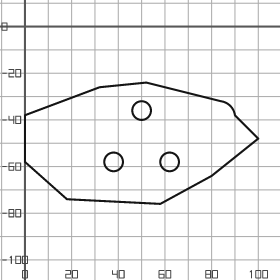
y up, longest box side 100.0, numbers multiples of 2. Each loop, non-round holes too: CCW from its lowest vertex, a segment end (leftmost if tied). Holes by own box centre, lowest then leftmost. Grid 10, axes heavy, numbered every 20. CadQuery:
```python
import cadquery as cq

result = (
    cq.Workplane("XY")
    .moveTo(58.0, -76.0)
    .lineTo(80.0, -64.0)
    .lineTo(100.0, -48.0)
    .lineTo(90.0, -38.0)
    .threePointArc((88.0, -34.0), (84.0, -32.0))
    .lineTo(52.0, -24.0)
    .lineTo(32.0, -26.0)
    .lineTo(0.0, -38.0)
    .lineTo(0.0, -58.0)
    .lineTo(18.0, -74.0)
    .close()
    .moveTo(38.0, -58.0)
    .circle(4.0)
    .moveTo(62.0, -58.0)
    .circle(4.0)
    .moveTo(50.0, -36.0)
    .circle(4.0)
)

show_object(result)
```